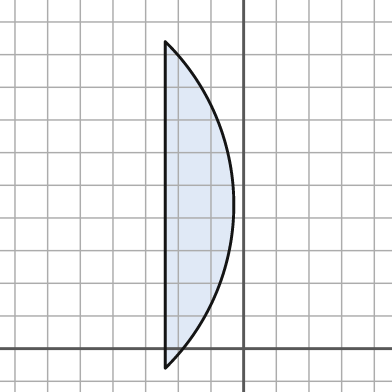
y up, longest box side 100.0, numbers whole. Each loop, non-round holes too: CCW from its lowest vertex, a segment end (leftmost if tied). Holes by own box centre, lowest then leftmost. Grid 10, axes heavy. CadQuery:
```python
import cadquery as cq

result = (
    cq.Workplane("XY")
    .moveTo(-24.0, -6.0)
    .threePointArc((-3.0, 44.0), (-24.0, 94.0))
    .close()
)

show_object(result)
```